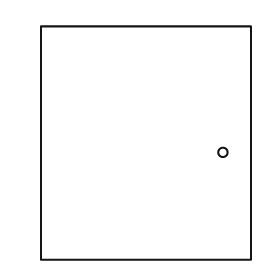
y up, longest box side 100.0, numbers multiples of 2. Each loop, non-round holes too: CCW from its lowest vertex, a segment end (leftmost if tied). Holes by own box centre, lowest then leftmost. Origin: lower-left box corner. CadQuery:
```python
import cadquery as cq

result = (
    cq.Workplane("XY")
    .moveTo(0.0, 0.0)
    .lineTo(90.0, 0.0)
    .lineTo(90.0, 100.0)
    .lineTo(0.0, 100.0)
    .close()
    .moveTo(78.0, 46.0)
    .circle(2.0)
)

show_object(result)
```